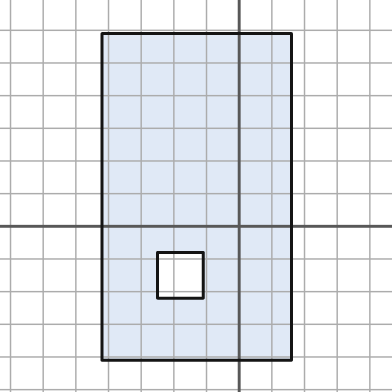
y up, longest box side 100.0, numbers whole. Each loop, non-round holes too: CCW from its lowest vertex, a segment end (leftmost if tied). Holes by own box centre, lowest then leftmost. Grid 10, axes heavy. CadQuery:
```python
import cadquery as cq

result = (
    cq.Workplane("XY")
    .moveTo(-42.0, -41.0)
    .lineTo(16.0, -41.0)
    .lineTo(16.0, 59.0)
    .lineTo(-42.0, 59.0)
    .close()
    .moveTo(-25.0, -22.0)
    .lineTo(-11.0, -22.0)
    .lineTo(-11.0, -8.0)
    .lineTo(-25.0, -8.0)
    .close()
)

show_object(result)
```